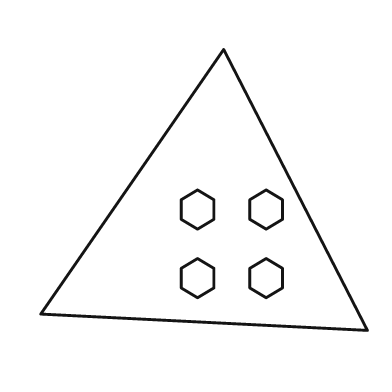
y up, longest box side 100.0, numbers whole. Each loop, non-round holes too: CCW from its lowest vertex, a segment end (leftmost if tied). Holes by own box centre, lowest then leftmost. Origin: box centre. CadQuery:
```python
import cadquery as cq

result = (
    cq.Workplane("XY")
    .moveTo(50.0, -43.0)
    .lineTo(6.0, 43.0)
    .lineTo(-50.0, -38.0)
    .close()
    .moveTo(-2.0, -33.0)
    .lineTo(3.0, -30.0)
    .lineTo(3.0, -24.0)
    .lineTo(-2.0, -21.0)
    .lineTo(-7.0, -24.0)
    .lineTo(-7.0, -30.0)
    .close()
    .moveTo(19.0, -33.0)
    .lineTo(24.0, -30.0)
    .lineTo(24.0, -24.0)
    .lineTo(19.0, -21.0)
    .lineTo(14.0, -24.0)
    .lineTo(14.0, -30.0)
    .close()
    .moveTo(-2.0, -12.0)
    .lineTo(3.0, -9.0)
    .lineTo(3.0, -3.0)
    .lineTo(-2.0, 0.0)
    .lineTo(-7.0, -3.0)
    .lineTo(-7.0, -9.0)
    .close()
    .moveTo(19.0, -12.0)
    .lineTo(24.0, -9.0)
    .lineTo(24.0, -3.0)
    .lineTo(19.0, 0.0)
    .lineTo(14.0, -3.0)
    .lineTo(14.0, -9.0)
    .close()
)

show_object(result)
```